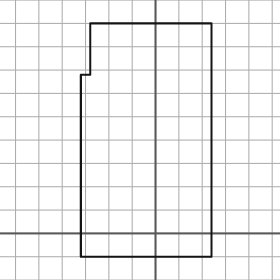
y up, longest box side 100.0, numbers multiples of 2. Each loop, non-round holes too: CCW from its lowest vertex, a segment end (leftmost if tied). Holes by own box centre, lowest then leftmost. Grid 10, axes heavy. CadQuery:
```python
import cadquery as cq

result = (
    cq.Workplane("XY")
    .moveTo(-32.0, -10.0)
    .lineTo(24.0, -10.0)
    .lineTo(24.0, 90.0)
    .lineTo(-28.0, 90.0)
    .lineTo(-28.0, 68.0)
    .lineTo(-32.0, 68.0)
    .close()
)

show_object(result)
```